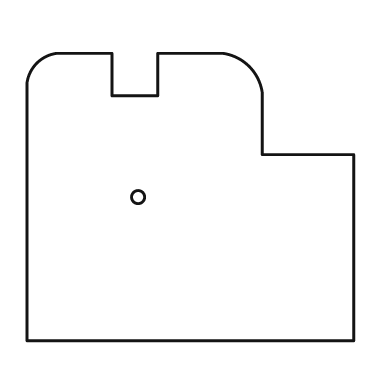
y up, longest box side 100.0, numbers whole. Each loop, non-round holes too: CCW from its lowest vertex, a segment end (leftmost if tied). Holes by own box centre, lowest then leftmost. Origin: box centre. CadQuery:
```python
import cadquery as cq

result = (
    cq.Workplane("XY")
    .moveTo(-50.0, -44.0)
    .lineTo(50.0, -44.0)
    .lineTo(50.0, 13.0)
    .lineTo(22.0, 13.0)
    .lineTo(22.0, 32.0)
    .threePointArc((18.0, 40.0), (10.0, 44.0))
    .lineTo(-10.0, 44.0)
    .lineTo(-10.0, 31.0)
    .lineTo(-24.0, 31.0)
    .lineTo(-24.0, 44.0)
    .lineTo(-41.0, 44.0)
    .threePointArc((-47.0, 41.0), (-50.0, 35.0))
    .close()
    .moveTo(-16.0, 0.0)
    .circle(2.0)
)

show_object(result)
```